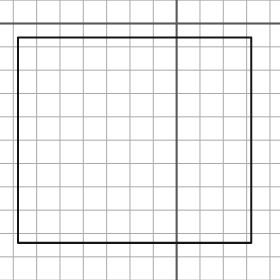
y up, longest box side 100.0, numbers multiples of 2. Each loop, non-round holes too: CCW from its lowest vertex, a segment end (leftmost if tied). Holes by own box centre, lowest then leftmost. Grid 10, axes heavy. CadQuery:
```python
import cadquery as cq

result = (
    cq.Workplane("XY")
    .moveTo(-68.0, -94.0)
    .lineTo(32.0, -94.0)
    .lineTo(32.0, -6.0)
    .lineTo(-68.0, -6.0)
    .close()
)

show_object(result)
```